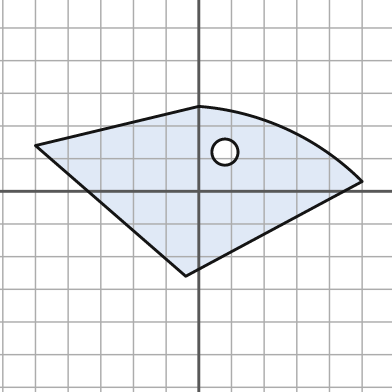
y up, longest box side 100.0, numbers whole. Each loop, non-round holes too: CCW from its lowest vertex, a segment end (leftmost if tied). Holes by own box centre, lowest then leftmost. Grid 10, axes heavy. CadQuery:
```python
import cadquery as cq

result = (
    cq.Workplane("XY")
    .moveTo(-4.0, -26.0)
    .lineTo(50.0, 3.0)
    .threePointArc((27.0, 19.0), (0.0, 26.0))
    .lineTo(-50.0, 14.0)
    .close()
    .moveTo(8.0, 12.0)
    .circle(4.0)
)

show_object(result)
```